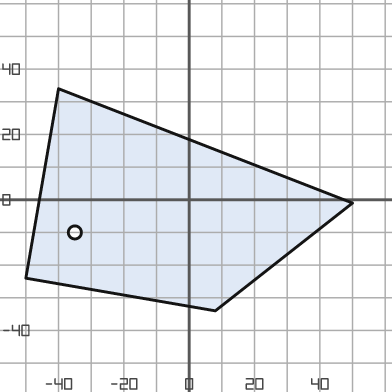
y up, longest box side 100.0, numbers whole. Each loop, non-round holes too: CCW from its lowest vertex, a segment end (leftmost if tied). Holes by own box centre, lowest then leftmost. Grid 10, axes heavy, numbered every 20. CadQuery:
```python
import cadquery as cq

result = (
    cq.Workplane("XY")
    .moveTo(8.0, -34.0)
    .lineTo(50.0, -1.0)
    .lineTo(-40.0, 34.0)
    .lineTo(-50.0, -24.0)
    .close()
    .moveTo(-35.0, -10.0)
    .circle(2.0)
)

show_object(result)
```